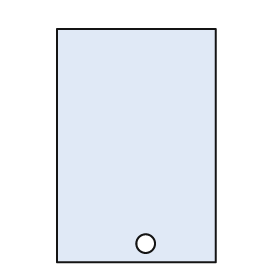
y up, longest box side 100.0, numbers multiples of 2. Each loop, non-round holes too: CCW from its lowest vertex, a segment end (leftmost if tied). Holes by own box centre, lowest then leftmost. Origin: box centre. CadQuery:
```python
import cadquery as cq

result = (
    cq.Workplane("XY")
    .moveTo(-34.0, -50.0)
    .lineTo(34.0, -50.0)
    .lineTo(34.0, 50.0)
    .lineTo(-34.0, 50.0)
    .close()
    .moveTo(4.0, -42.0)
    .circle(4.0)
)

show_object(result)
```